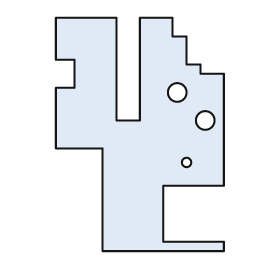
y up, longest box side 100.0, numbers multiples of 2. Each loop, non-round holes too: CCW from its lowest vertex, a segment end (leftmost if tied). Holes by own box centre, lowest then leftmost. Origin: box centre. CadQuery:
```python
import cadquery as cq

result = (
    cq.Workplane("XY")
    .moveTo(-16.0, -50.0)
    .lineTo(36.0, -50.0)
    .lineTo(36.0, -46.0)
    .lineTo(10.0, -46.0)
    .lineTo(10.0, -22.0)
    .lineTo(36.0, -22.0)
    .lineTo(36.0, 26.0)
    .lineTo(26.0, 26.0)
    .lineTo(26.0, 30.0)
    .lineTo(20.0, 30.0)
    .lineTo(20.0, 42.0)
    .lineTo(14.0, 42.0)
    .lineTo(14.0, 50.0)
    .lineTo(0.0, 50.0)
    .lineTo(0.0, 6.0)
    .lineTo(-10.0, 6.0)
    .lineTo(-10.0, 50.0)
    .lineTo(-36.0, 50.0)
    .lineTo(-36.0, 32.0)
    .lineTo(-28.0, 32.0)
    .lineTo(-28.0, 20.0)
    .lineTo(-36.0, 20.0)
    .lineTo(-36.0, -6.0)
    .lineTo(-16.0, -6.0)
    .close()
    .moveTo(20.0, -12.0)
    .circle(2.0)
    .moveTo(28.0, 6.0)
    .circle(4.0)
    .moveTo(16.0, 18.0)
    .circle(4.0)
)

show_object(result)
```